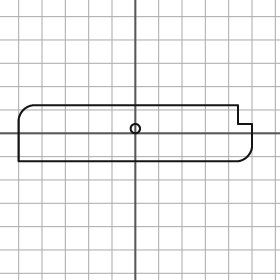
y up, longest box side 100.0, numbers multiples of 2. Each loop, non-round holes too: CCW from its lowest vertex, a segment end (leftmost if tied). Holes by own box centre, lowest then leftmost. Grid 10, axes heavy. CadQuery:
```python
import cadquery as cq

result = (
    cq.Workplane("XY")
    .moveTo(-50.0, -12.0)
    .lineTo(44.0, -12.0)
    .threePointArc((48.0, -10.0), (50.0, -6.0))
    .lineTo(50.0, 4.0)
    .lineTo(44.0, 4.0)
    .lineTo(44.0, 12.0)
    .lineTo(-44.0, 12.0)
    .threePointArc((-48.0, 10.0), (-50.0, 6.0))
    .close()
    .moveTo(0.0, 2.0)
    .circle(2.0)
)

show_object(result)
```